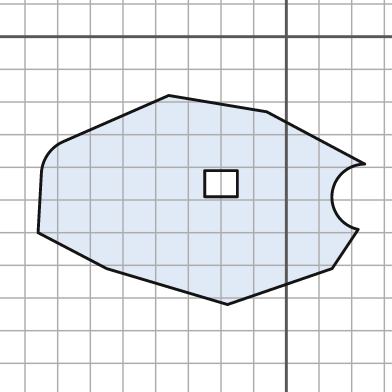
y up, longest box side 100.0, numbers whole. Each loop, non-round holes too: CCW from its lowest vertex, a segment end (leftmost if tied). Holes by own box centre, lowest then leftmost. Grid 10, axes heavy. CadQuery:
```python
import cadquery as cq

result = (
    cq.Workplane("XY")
    .moveTo(-18.0, -82.0)
    .lineTo(14.0, -71.0)
    .lineTo(22.0, -59.0)
    .threePointArc((14.0, -48.0), (24.0, -39.0))
    .lineTo(-6.0, -23.0)
    .lineTo(-36.0, -18.0)
    .lineTo(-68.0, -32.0)
    .threePointArc((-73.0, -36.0), (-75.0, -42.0))
    .lineTo(-76.0, -60.0)
    .lineTo(-55.0, -71.0)
    .close()
    .moveTo(-25.0, -49.0)
    .lineTo(-15.0, -49.0)
    .lineTo(-15.0, -41.0)
    .lineTo(-25.0, -41.0)
    .close()
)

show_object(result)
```